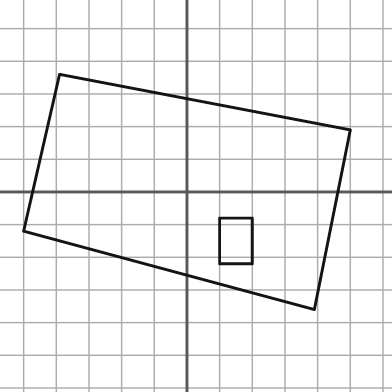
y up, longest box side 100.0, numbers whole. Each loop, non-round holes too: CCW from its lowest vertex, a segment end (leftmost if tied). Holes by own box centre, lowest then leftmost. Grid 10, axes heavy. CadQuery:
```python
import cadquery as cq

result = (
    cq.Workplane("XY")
    .moveTo(39.0, -36.0)
    .lineTo(50.0, 19.0)
    .lineTo(-39.0, 36.0)
    .lineTo(-50.0, -12.0)
    .close()
    .moveTo(10.0, -22.0)
    .lineTo(20.0, -22.0)
    .lineTo(20.0, -8.0)
    .lineTo(10.0, -8.0)
    .close()
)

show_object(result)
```